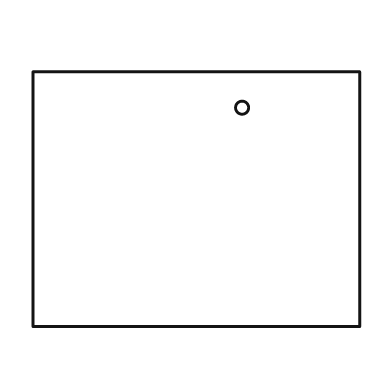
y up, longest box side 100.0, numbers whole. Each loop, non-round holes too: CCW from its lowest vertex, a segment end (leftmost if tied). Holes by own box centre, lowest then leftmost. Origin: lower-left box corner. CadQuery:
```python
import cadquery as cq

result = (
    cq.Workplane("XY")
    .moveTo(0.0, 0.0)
    .lineTo(100.0, 0.0)
    .lineTo(100.0, 78.0)
    .lineTo(0.0, 78.0)
    .close()
    .moveTo(64.0, 67.0)
    .circle(2.0)
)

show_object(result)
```